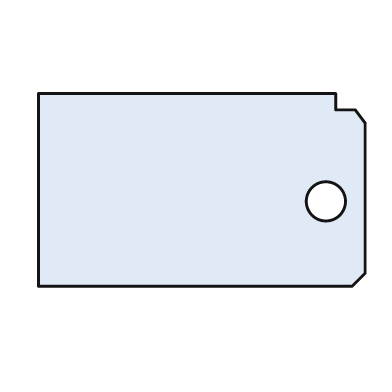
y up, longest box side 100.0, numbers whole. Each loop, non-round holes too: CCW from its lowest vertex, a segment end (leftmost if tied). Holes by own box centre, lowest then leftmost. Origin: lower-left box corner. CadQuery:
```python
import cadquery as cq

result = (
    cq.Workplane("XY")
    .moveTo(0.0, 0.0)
    .lineTo(96.0, 0.0)
    .lineTo(100.0, 4.0)
    .lineTo(100.0, 50.0)
    .lineTo(97.0, 54.0)
    .lineTo(91.0, 54.0)
    .lineTo(91.0, 59.0)
    .lineTo(0.0, 59.0)
    .close()
    .moveTo(88.0, 26.0)
    .circle(6.0)
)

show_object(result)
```